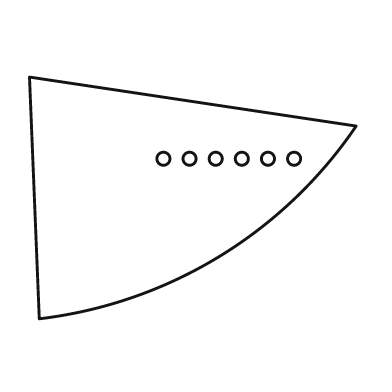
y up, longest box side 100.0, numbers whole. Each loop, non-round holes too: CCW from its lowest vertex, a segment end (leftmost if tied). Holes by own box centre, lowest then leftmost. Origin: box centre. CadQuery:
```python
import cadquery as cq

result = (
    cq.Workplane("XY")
    .moveTo(-47.0, -37.0)
    .threePointArc((8.0, -18.0), (50.0, 22.0))
    .lineTo(-50.0, 37.0)
    .close()
    .moveTo(-9.0, 12.0)
    .circle(2.0)
    .moveTo(-1.0, 12.0)
    .circle(2.0)
    .moveTo(7.0, 12.0)
    .circle(2.0)
    .moveTo(15.0, 12.0)
    .circle(2.0)
    .moveTo(23.0, 12.0)
    .circle(2.0)
    .moveTo(31.0, 12.0)
    .circle(2.0)
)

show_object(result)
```